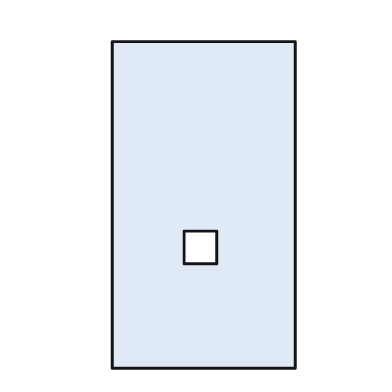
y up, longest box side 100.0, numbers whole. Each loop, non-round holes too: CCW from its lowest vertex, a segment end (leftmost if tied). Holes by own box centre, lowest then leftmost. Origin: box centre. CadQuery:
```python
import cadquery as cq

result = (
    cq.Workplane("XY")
    .moveTo(-28.0, -50.0)
    .lineTo(28.0, -50.0)
    .lineTo(28.0, 50.0)
    .lineTo(-28.0, 50.0)
    .close()
    .moveTo(-6.0, -18.0)
    .lineTo(4.0, -18.0)
    .lineTo(4.0, -8.0)
    .lineTo(-6.0, -8.0)
    .close()
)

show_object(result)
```